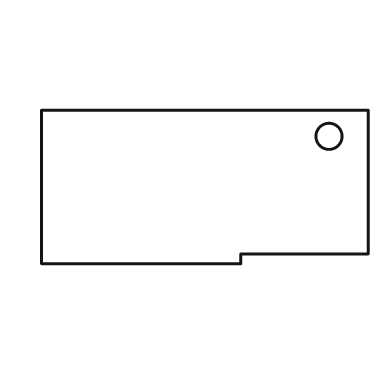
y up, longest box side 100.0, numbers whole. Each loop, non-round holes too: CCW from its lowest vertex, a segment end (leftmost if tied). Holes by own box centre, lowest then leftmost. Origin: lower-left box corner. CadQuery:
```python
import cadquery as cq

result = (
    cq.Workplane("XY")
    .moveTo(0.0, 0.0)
    .lineTo(61.0, 0.0)
    .lineTo(61.0, 3.0)
    .lineTo(100.0, 3.0)
    .lineTo(100.0, 47.0)
    .lineTo(0.0, 47.0)
    .close()
    .moveTo(88.0, 39.0)
    .circle(4.0)
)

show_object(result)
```